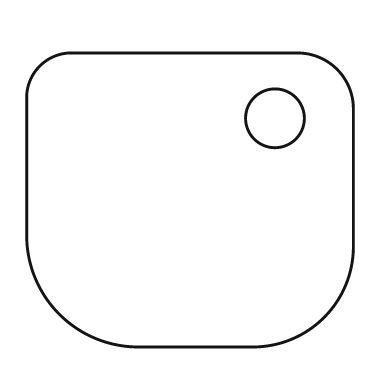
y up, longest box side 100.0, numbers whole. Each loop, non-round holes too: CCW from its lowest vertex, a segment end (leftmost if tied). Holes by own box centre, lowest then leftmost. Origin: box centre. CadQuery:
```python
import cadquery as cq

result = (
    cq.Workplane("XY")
    .moveTo(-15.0, -45.0)
    .lineTo(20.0, -45.0)
    .threePointArc((41.0, -36.0), (50.0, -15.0))
    .lineTo(50.0, 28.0)
    .threePointArc((45.0, 40.0), (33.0, 45.0))
    .lineTo(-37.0, 45.0)
    .threePointArc((-46.0, 41.0), (-50.0, 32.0))
    .lineTo(-50.0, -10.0)
    .threePointArc((-40.0, -35.0), (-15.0, -45.0))
    .close()
    .moveTo(26.0, 25.0)
    .circle(9.0)
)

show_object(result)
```